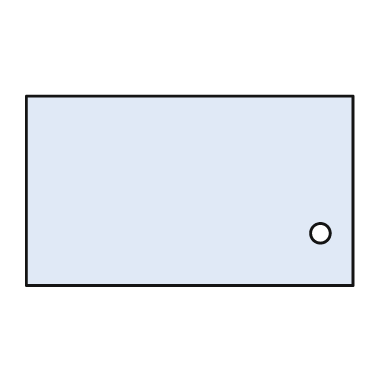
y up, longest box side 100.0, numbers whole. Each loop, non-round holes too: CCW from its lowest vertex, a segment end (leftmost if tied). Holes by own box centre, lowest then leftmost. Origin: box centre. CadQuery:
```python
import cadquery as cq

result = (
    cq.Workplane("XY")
    .moveTo(-50.0, -29.0)
    .lineTo(50.0, -29.0)
    .lineTo(50.0, 29.0)
    .lineTo(-50.0, 29.0)
    .close()
    .moveTo(40.0, -13.0)
    .circle(3.0)
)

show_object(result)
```